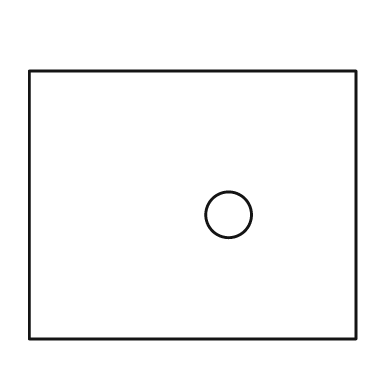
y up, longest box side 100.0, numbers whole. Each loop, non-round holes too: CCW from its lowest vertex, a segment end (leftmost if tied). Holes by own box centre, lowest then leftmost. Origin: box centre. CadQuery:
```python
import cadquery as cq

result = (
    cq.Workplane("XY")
    .moveTo(-50.0, -41.0)
    .lineTo(50.0, -41.0)
    .lineTo(50.0, 41.0)
    .lineTo(-50.0, 41.0)
    .close()
    .moveTo(11.0, -3.0)
    .circle(7.0)
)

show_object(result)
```